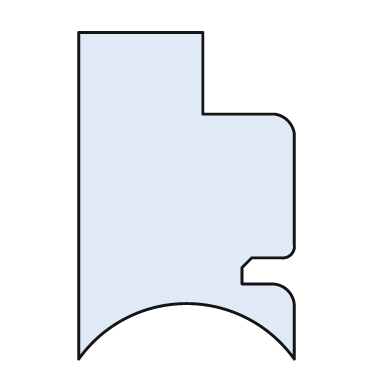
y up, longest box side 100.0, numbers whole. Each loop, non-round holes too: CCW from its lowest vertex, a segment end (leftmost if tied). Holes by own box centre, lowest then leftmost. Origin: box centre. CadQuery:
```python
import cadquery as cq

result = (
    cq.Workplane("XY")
    .moveTo(-33.0, -50.0)
    .threePointArc((0.0, -33.0), (33.0, -50.0))
    .lineTo(33.0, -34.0)
    .threePointArc((31.0, -29.0), (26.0, -27.0))
    .lineTo(17.0, -27.0)
    .lineTo(17.0, -22.0)
    .lineTo(20.0, -19.0)
    .lineTo(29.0, -19.0)
    .threePointArc((32.0, -18.0), (33.0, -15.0))
    .lineTo(33.0, 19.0)
    .threePointArc((31.0, 23.0), (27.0, 25.0))
    .lineTo(5.0, 25.0)
    .lineTo(5.0, 50.0)
    .lineTo(-33.0, 50.0)
    .close()
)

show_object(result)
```